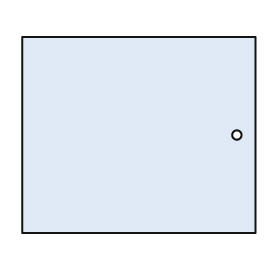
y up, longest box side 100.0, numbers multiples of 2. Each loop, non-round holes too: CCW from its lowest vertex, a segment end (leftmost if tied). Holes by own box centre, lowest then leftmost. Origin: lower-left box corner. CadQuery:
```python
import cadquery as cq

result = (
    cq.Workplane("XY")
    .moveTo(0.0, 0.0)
    .lineTo(100.0, 0.0)
    .lineTo(100.0, 84.0)
    .lineTo(0.0, 84.0)
    .close()
    .moveTo(92.0, 42.0)
    .circle(2.0)
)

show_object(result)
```